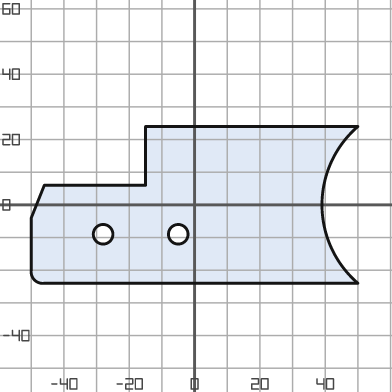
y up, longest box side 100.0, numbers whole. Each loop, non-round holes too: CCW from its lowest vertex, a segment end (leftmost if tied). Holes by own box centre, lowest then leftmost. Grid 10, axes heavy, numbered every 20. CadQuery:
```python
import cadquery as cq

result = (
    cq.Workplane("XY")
    .moveTo(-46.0, -24.0)
    .lineTo(50.0, -24.0)
    .threePointArc((39.0, 0.0), (50.0, 24.0))
    .lineTo(-15.0, 24.0)
    .lineTo(-15.0, 6.0)
    .lineTo(-46.0, 6.0)
    .lineTo(-50.0, -4.0)
    .lineTo(-50.0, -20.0)
    .threePointArc((-49.0, -23.0), (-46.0, -24.0))
    .close()
    .moveTo(-28.0, -9.0)
    .circle(3.0)
    .moveTo(-5.0, -9.0)
    .circle(3.0)
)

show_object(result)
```